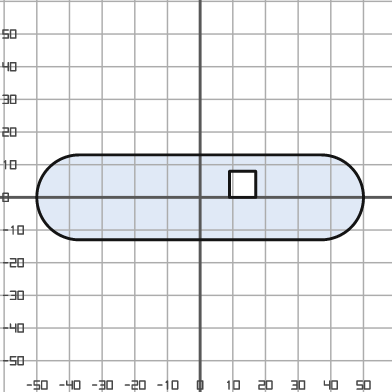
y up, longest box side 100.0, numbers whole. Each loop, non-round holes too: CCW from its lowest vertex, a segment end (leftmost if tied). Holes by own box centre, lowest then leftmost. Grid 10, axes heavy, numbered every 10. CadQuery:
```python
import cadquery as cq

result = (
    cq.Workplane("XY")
    .moveTo(-37.0, -13.0)
    .lineTo(37.0, -13.0)
    .threePointArc((50.0, 0.0), (37.0, 13.0))
    .lineTo(-37.0, 13.0)
    .threePointArc((-50.0, 0.0), (-37.0, -13.0))
    .close()
    .moveTo(9.0, 0.0)
    .lineTo(17.0, 0.0)
    .lineTo(17.0, 8.0)
    .lineTo(9.0, 8.0)
    .close()
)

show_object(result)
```